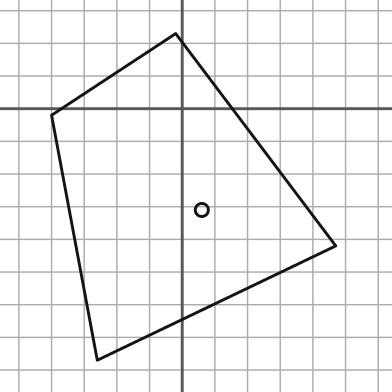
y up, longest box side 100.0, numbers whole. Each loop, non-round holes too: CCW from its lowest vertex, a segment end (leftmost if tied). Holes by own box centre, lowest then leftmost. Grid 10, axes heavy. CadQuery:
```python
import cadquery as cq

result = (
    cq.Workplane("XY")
    .moveTo(-26.0, -77.0)
    .lineTo(47.0, -42.0)
    .lineTo(-2.0, 23.0)
    .lineTo(-40.0, -2.0)
    .close()
    .moveTo(6.0, -31.0)
    .circle(2.0)
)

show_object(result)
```